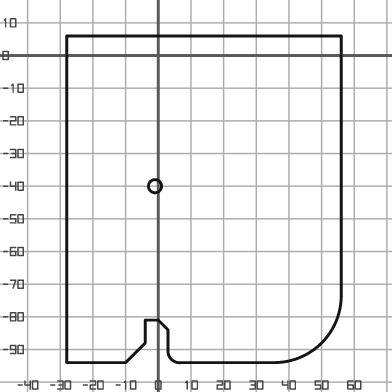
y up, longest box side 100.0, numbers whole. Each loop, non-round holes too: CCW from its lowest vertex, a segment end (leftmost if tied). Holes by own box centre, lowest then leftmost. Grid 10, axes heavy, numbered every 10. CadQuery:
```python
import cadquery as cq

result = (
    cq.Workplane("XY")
    .moveTo(-28.0, -94.0)
    .lineTo(-10.0, -94.0)
    .lineTo(-4.0, -88.0)
    .lineTo(-4.0, -81.0)
    .lineTo(0.0, -81.0)
    .lineTo(3.0, -84.0)
    .lineTo(3.0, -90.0)
    .threePointArc((4.0, -93.0), (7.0, -94.0))
    .lineTo(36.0, -94.0)
    .threePointArc((50.0, -88.0), (56.0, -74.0))
    .lineTo(56.0, 6.0)
    .lineTo(-28.0, 6.0)
    .close()
    .moveTo(-1.0, -40.0)
    .circle(2.0)
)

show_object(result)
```